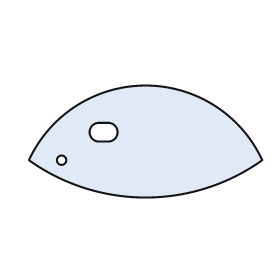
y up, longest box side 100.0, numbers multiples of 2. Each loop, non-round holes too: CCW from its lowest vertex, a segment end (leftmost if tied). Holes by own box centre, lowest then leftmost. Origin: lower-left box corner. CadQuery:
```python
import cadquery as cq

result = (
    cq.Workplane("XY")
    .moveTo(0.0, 16.0)
    .threePointArc((50.0, 0.0), (100.0, 16.0))
    .threePointArc((50.0, 48.0), (0.0, 16.0))
    .close()
    .moveTo(14.0, 16.0)
    .circle(2.0)
    .moveTo(30.0, 24.0)
    .lineTo(34.0, 24.0)
    .threePointArc((38.0, 28.0), (34.0, 32.0))
    .lineTo(30.0, 32.0)
    .threePointArc((26.0, 28.0), (30.0, 24.0))
    .close()
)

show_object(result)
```